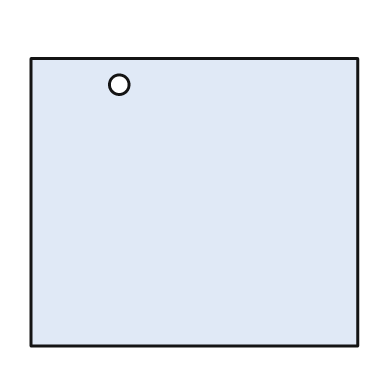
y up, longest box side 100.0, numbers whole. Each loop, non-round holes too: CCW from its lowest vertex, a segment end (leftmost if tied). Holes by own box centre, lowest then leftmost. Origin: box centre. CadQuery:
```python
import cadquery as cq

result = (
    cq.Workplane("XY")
    .moveTo(-50.0, -44.0)
    .lineTo(50.0, -44.0)
    .lineTo(50.0, 44.0)
    .lineTo(-50.0, 44.0)
    .close()
    .moveTo(-23.0, 36.0)
    .circle(3.0)
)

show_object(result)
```